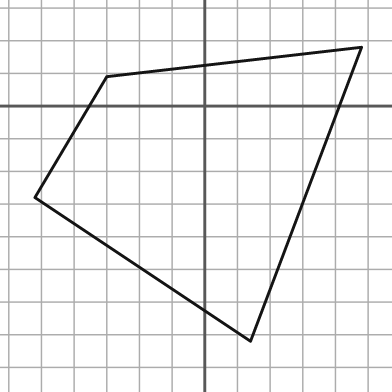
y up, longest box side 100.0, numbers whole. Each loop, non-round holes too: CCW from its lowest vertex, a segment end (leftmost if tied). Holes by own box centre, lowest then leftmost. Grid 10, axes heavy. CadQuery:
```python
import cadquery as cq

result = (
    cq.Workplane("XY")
    .moveTo(14.0, -72.0)
    .lineTo(48.0, 18.0)
    .lineTo(-30.0, 9.0)
    .lineTo(-52.0, -28.0)
    .close()
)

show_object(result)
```